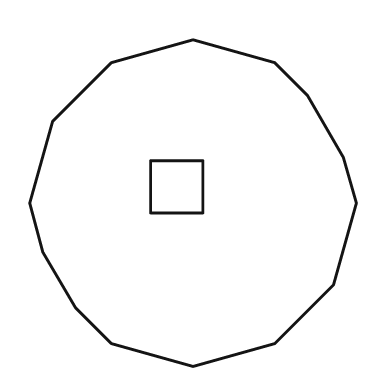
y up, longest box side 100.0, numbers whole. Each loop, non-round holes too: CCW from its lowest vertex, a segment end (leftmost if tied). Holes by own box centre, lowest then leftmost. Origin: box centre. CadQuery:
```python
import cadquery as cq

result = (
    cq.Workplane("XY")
    .moveTo(0.0, -50.0)
    .lineTo(25.0, -43.0)
    .lineTo(43.0, -25.0)
    .lineTo(50.0, 0.0)
    .lineTo(46.0, 14.0)
    .lineTo(35.0, 33.0)
    .lineTo(25.0, 43.0)
    .lineTo(0.0, 50.0)
    .lineTo(-25.0, 43.0)
    .lineTo(-43.0, 25.0)
    .lineTo(-50.0, 0.0)
    .lineTo(-46.0, -15.0)
    .lineTo(-36.0, -32.0)
    .lineTo(-25.0, -43.0)
    .close()
    .moveTo(-13.0, -3.0)
    .lineTo(3.0, -3.0)
    .lineTo(3.0, 13.0)
    .lineTo(-13.0, 13.0)
    .close()
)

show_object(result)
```